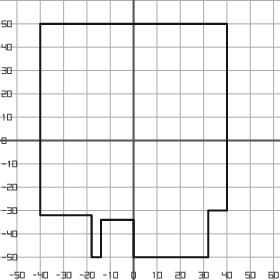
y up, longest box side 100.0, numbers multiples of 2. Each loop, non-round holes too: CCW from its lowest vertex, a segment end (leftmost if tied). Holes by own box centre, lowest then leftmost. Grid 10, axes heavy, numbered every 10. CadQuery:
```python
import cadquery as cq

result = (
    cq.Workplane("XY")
    .moveTo(-18.0, -50.0)
    .lineTo(-14.0, -50.0)
    .lineTo(-14.0, -34.0)
    .lineTo(0.0, -34.0)
    .lineTo(0.0, -50.0)
    .lineTo(32.0, -50.0)
    .lineTo(32.0, -30.0)
    .lineTo(40.0, -30.0)
    .lineTo(40.0, 50.0)
    .lineTo(-40.0, 50.0)
    .lineTo(-40.0, -32.0)
    .lineTo(-18.0, -32.0)
    .close()
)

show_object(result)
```